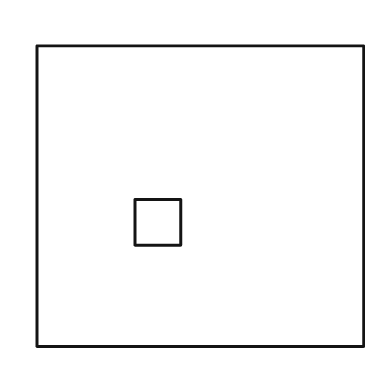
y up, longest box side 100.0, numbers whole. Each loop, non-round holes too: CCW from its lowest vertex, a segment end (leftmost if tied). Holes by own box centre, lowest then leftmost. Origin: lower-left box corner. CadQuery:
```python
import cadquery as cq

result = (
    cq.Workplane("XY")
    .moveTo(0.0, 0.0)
    .lineTo(100.0, 0.0)
    .lineTo(100.0, 92.0)
    .lineTo(0.0, 92.0)
    .close()
    .moveTo(30.0, 31.0)
    .lineTo(44.0, 31.0)
    .lineTo(44.0, 45.0)
    .lineTo(30.0, 45.0)
    .close()
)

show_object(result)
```